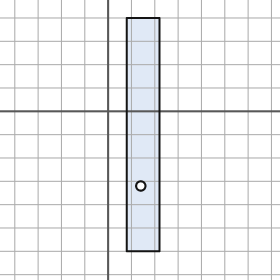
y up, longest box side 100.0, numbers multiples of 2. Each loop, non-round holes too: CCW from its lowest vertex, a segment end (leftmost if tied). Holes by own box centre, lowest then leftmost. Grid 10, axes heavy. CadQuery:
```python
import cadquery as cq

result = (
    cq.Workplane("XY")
    .moveTo(8.0, -60.0)
    .lineTo(22.0, -60.0)
    .lineTo(22.0, 40.0)
    .lineTo(8.0, 40.0)
    .close()
    .moveTo(14.0, -32.0)
    .circle(2.0)
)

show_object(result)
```